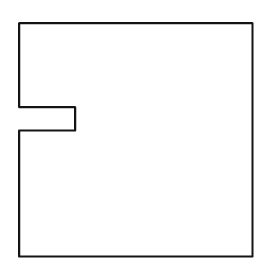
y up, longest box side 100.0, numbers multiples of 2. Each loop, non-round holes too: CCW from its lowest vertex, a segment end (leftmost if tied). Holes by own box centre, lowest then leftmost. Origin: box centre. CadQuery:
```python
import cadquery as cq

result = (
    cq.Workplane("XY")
    .moveTo(-50.0, -50.0)
    .lineTo(50.0, -50.0)
    .lineTo(50.0, 50.0)
    .lineTo(-50.0, 50.0)
    .lineTo(-50.0, 14.0)
    .lineTo(-26.0, 14.0)
    .lineTo(-26.0, 4.0)
    .lineTo(-50.0, 4.0)
    .close()
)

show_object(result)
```